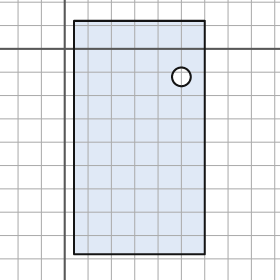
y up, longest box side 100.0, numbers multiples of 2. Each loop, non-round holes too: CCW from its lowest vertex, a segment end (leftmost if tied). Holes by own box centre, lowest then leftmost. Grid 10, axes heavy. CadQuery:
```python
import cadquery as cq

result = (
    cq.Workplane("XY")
    .moveTo(4.0, -88.0)
    .lineTo(60.0, -88.0)
    .lineTo(60.0, 12.0)
    .lineTo(4.0, 12.0)
    .close()
    .moveTo(50.0, -12.0)
    .circle(4.0)
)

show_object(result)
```